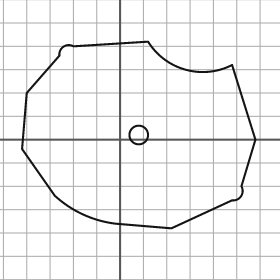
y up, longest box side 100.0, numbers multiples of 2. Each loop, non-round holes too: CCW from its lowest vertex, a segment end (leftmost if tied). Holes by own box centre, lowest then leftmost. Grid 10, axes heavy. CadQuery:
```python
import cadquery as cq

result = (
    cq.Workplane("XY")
    .moveTo(22.0, -38.0)
    .lineTo(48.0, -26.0)
    .threePointArc((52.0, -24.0), (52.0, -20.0))
    .lineTo(58.0, 0.0)
    .lineTo(48.0, 32.0)
    .threePointArc((28.0, 30.0), (12.0, 42.0))
    .lineTo(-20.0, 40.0)
    .threePointArc((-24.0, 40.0), (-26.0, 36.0))
    .lineTo(-40.0, 20.0)
    .lineTo(-42.0, -4.0)
    .lineTo(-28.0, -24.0)
    .threePointArc((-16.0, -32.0), (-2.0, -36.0))
    .close()
    .moveTo(8.0, 2.0)
    .circle(4.0)
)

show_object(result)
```